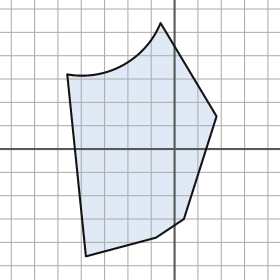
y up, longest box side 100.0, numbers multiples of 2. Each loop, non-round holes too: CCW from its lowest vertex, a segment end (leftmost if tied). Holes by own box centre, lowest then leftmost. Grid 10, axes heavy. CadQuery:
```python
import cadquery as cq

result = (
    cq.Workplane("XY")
    .moveTo(-38.0, -46.0)
    .lineTo(-8.0, -38.0)
    .lineTo(4.0, -30.0)
    .lineTo(18.0, 14.0)
    .lineTo(-6.0, 54.0)
    .threePointArc((-22.0, 36.0), (-46.0, 32.0))
    .close()
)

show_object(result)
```